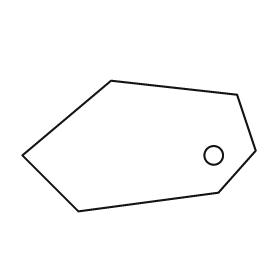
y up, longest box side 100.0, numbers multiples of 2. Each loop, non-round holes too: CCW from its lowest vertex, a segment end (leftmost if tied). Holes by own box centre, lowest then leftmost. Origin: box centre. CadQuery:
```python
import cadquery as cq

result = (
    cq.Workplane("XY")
    .moveTo(-26.0, -28.0)
    .lineTo(34.0, -20.0)
    .lineTo(50.0, -2.0)
    .lineTo(42.0, 22.0)
    .lineTo(-12.0, 28.0)
    .lineTo(-50.0, -4.0)
    .close()
    .moveTo(32.0, -4.0)
    .circle(4.0)
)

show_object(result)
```